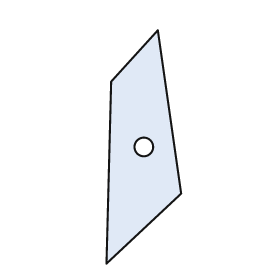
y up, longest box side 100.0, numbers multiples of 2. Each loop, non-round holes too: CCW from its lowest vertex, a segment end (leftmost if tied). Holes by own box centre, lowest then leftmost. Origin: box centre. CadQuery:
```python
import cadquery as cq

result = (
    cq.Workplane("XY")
    .moveTo(-16.0, -50.0)
    .lineTo(16.0, -20.0)
    .lineTo(6.0, 50.0)
    .lineTo(-14.0, 28.0)
    .close()
    .moveTo(0.0, 0.0)
    .circle(4.0)
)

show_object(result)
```